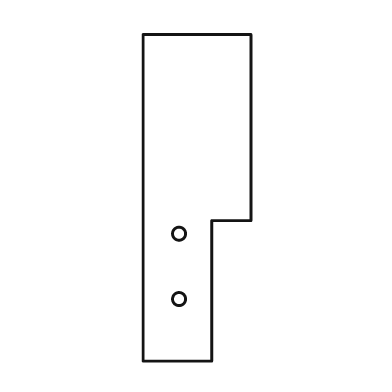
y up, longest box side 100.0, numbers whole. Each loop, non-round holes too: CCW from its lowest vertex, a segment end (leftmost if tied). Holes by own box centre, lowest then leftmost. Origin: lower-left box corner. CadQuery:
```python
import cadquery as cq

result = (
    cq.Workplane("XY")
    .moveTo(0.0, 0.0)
    .lineTo(21.0, 0.0)
    .lineTo(21.0, 43.0)
    .lineTo(33.0, 43.0)
    .lineTo(33.0, 100.0)
    .lineTo(0.0, 100.0)
    .close()
    .moveTo(11.0, 19.0)
    .circle(2.0)
    .moveTo(11.0, 39.0)
    .circle(2.0)
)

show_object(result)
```